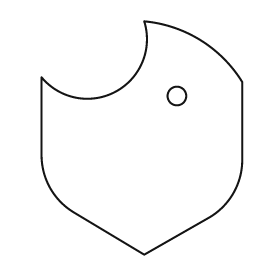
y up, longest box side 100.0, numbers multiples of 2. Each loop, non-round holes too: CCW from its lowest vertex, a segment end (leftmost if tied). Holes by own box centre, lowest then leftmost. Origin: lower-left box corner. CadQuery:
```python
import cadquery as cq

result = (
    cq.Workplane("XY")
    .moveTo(44.0, 0.0)
    .lineTo(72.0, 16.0)
    .threePointArc((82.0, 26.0), (86.0, 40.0))
    .lineTo(86.0, 74.0)
    .threePointArc((68.0, 92.0), (44.0, 100.0))
    .threePointArc((32.0, 70.0), (0.0, 76.0))
    .lineTo(0.0, 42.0)
    .threePointArc((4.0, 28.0), (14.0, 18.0))
    .close()
    .moveTo(58.0, 68.0)
    .circle(4.0)
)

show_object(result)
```